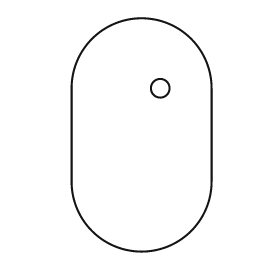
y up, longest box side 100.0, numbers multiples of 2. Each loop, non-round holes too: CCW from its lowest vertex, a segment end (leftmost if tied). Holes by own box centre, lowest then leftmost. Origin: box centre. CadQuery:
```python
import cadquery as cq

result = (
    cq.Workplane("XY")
    .moveTo(-30.0, -20.0)
    .threePointArc((0.0, -50.0), (30.0, -20.0))
    .lineTo(30.0, 20.0)
    .threePointArc((0.0, 50.0), (-30.0, 20.0))
    .close()
    .moveTo(8.0, 20.0)
    .circle(4.0)
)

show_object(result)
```